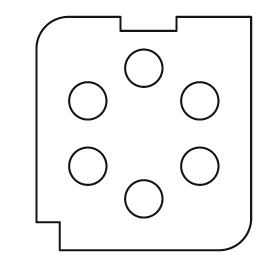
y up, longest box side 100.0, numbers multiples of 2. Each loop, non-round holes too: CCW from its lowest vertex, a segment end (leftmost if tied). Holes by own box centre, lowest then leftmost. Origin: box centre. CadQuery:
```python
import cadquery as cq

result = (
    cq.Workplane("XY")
    .moveTo(-36.0, -50.0)
    .lineTo(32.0, -50.0)
    .threePointArc((42.0, -46.0), (46.0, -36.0))
    .lineTo(46.0, 50.0)
    .lineTo(14.0, 50.0)
    .lineTo(14.0, 44.0)
    .lineTo(-10.0, 44.0)
    .lineTo(-10.0, 50.0)
    .lineTo(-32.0, 50.0)
    .threePointArc((-42.0, 46.0), (-46.0, 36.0))
    .lineTo(-46.0, -38.0)
    .lineTo(-36.0, -38.0)
    .close()
    .moveTo(0.0, -28.0)
    .circle(8.0)
    .moveTo(-24.0, -14.0)
    .circle(8.0)
    .moveTo(24.0, -14.0)
    .circle(8.0)
    .moveTo(-24.0, 14.0)
    .circle(8.0)
    .moveTo(24.0, 14.0)
    .circle(8.0)
    .moveTo(0.0, 28.0)
    .circle(8.0)
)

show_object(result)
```